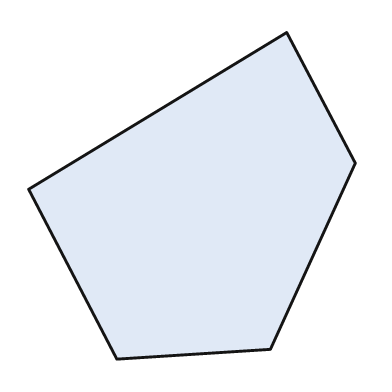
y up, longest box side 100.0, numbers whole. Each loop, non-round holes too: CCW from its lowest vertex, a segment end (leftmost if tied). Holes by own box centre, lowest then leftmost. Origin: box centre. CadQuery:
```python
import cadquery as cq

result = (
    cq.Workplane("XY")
    .moveTo(-23.0, -50.0)
    .lineTo(24.0, -47.0)
    .lineTo(50.0, 10.0)
    .lineTo(29.0, 50.0)
    .lineTo(-50.0, 2.0)
    .close()
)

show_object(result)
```